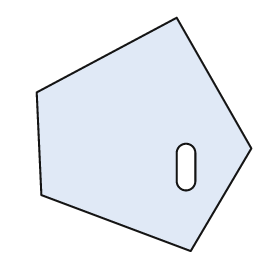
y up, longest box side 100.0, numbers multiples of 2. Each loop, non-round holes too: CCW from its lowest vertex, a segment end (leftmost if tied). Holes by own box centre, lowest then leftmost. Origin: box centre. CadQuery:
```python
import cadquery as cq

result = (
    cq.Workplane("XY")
    .moveTo(20.0, -50.0)
    .lineTo(46.0, -6.0)
    .lineTo(14.0, 50.0)
    .lineTo(-46.0, 18.0)
    .lineTo(-44.0, -26.0)
    .close()
    .moveTo(14.0, -20.0)
    .threePointArc((18.0, -24.0), (22.0, -20.0))
    .lineTo(22.0, -8.0)
    .threePointArc((18.0, -4.0), (14.0, -8.0))
    .close()
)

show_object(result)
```